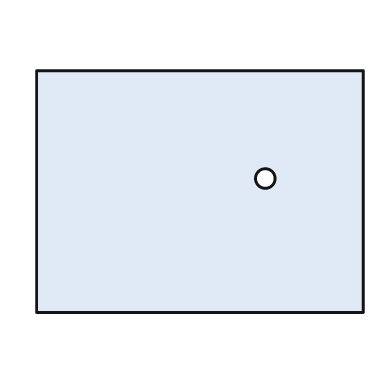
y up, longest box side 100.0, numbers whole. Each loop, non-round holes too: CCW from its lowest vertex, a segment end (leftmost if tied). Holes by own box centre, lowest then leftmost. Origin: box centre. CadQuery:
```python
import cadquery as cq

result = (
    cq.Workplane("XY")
    .moveTo(-50.0, -37.0)
    .lineTo(50.0, -37.0)
    .lineTo(50.0, 37.0)
    .lineTo(-50.0, 37.0)
    .close()
    .moveTo(20.0, 4.0)
    .circle(3.0)
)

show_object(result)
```